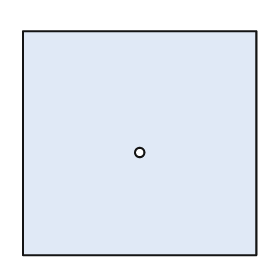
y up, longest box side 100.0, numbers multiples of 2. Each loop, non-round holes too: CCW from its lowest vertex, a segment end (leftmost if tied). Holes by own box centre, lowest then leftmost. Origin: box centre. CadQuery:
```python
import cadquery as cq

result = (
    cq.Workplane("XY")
    .moveTo(-50.0, -48.0)
    .lineTo(50.0, -48.0)
    .lineTo(50.0, 48.0)
    .lineTo(-50.0, 48.0)
    .close()
    .moveTo(0.0, -4.0)
    .circle(2.0)
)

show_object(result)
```